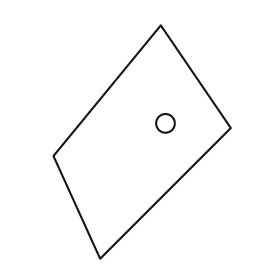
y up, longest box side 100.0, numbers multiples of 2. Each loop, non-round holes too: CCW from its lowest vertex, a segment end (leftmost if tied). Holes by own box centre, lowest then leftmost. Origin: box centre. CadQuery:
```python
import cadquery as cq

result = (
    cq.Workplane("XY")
    .moveTo(-18.0, -50.0)
    .lineTo(38.0, 6.0)
    .lineTo(8.0, 50.0)
    .lineTo(-38.0, -6.0)
    .close()
    .moveTo(10.0, 8.0)
    .circle(4.0)
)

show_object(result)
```